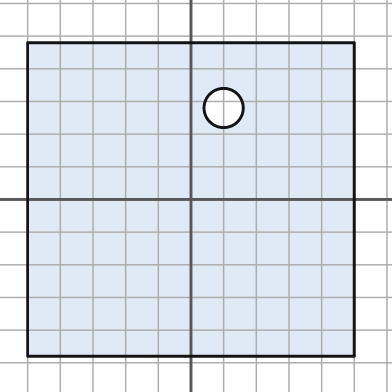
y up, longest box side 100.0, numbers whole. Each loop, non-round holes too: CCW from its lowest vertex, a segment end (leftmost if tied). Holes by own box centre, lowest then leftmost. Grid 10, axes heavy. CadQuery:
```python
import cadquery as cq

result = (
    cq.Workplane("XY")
    .moveTo(-50.0, -48.0)
    .lineTo(50.0, -48.0)
    .lineTo(50.0, 48.0)
    .lineTo(-50.0, 48.0)
    .close()
    .moveTo(10.0, 28.0)
    .circle(6.0)
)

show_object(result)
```